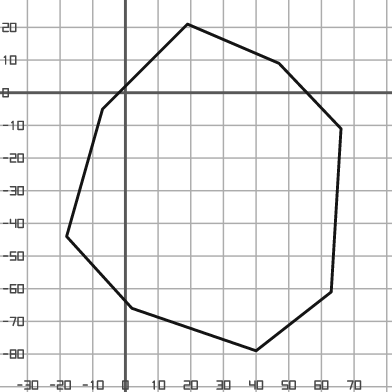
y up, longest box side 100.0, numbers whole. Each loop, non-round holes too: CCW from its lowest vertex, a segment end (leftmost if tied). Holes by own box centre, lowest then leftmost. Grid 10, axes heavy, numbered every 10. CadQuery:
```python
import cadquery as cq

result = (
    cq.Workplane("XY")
    .moveTo(40.0, -79.0)
    .lineTo(63.0, -61.0)
    .lineTo(66.0, -11.0)
    .lineTo(47.0, 9.0)
    .lineTo(19.0, 21.0)
    .lineTo(-7.0, -5.0)
    .lineTo(-18.0, -44.0)
    .lineTo(2.0, -66.0)
    .close()
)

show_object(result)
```